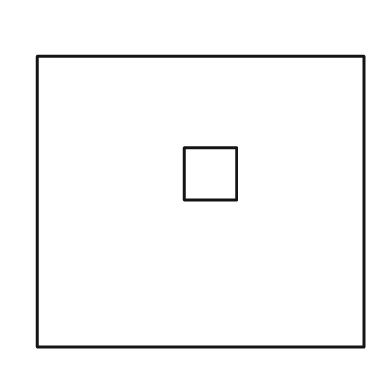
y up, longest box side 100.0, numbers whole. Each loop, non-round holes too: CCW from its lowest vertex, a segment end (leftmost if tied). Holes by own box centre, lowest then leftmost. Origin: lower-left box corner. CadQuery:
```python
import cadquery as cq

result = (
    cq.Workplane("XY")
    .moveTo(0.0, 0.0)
    .lineTo(100.0, 0.0)
    .lineTo(100.0, 89.0)
    .lineTo(0.0, 89.0)
    .close()
    .moveTo(45.0, 45.0)
    .lineTo(61.0, 45.0)
    .lineTo(61.0, 61.0)
    .lineTo(45.0, 61.0)
    .close()
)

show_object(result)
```